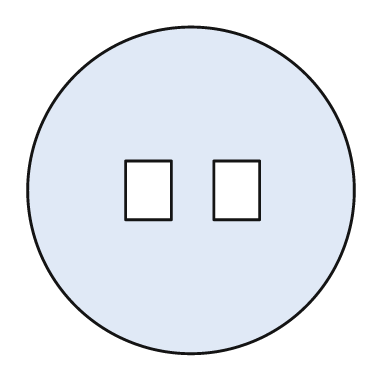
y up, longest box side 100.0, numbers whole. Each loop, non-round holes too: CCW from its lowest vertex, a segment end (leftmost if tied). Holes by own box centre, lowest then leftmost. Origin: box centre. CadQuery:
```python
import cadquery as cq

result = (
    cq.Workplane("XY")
    .moveTo(0.0, 0.0)
    .circle(50.0)
    .moveTo(-20.0, -9.0)
    .lineTo(-6.0, -9.0)
    .lineTo(-6.0, 9.0)
    .lineTo(-20.0, 9.0)
    .close()
    .moveTo(7.0, -9.0)
    .lineTo(21.0, -9.0)
    .lineTo(21.0, 9.0)
    .lineTo(7.0, 9.0)
    .close()
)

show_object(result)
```